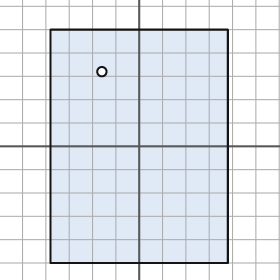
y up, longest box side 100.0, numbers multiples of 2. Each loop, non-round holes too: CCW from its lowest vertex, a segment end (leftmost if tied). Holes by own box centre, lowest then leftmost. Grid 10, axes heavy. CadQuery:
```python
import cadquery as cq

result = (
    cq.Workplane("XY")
    .moveTo(-38.0, -50.0)
    .lineTo(38.0, -50.0)
    .lineTo(38.0, 50.0)
    .lineTo(-38.0, 50.0)
    .close()
    .moveTo(-16.0, 32.0)
    .circle(2.0)
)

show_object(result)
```